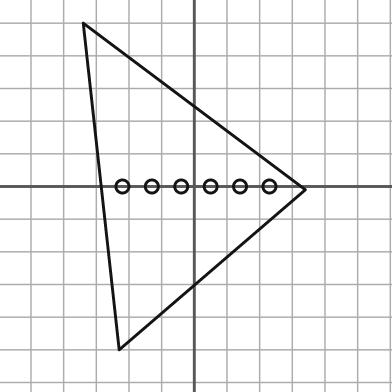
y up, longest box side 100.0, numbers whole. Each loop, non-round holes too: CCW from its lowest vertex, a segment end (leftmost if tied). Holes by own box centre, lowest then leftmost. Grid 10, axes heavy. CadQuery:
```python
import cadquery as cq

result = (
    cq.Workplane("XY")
    .moveTo(-23.0, -50.0)
    .lineTo(34.0, -1.0)
    .lineTo(-34.0, 50.0)
    .close()
    .moveTo(-22.0, 0.0)
    .circle(2.0)
    .moveTo(-13.0, 0.0)
    .circle(2.0)
    .moveTo(-4.0, 0.0)
    .circle(2.0)
    .moveTo(5.0, 0.0)
    .circle(2.0)
    .moveTo(14.0, 0.0)
    .circle(2.0)
    .moveTo(23.0, 0.0)
    .circle(2.0)
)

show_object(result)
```